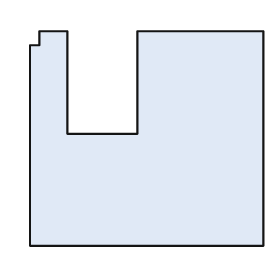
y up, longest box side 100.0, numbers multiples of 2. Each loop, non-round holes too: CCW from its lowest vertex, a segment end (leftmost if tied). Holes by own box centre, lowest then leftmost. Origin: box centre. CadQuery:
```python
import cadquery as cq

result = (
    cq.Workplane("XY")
    .moveTo(-50.0, -46.0)
    .lineTo(50.0, -46.0)
    .lineTo(50.0, 46.0)
    .lineTo(-4.0, 46.0)
    .lineTo(-4.0, 2.0)
    .lineTo(-34.0, 2.0)
    .lineTo(-34.0, 46.0)
    .lineTo(-46.0, 46.0)
    .lineTo(-46.0, 40.0)
    .lineTo(-50.0, 40.0)
    .close()
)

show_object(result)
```